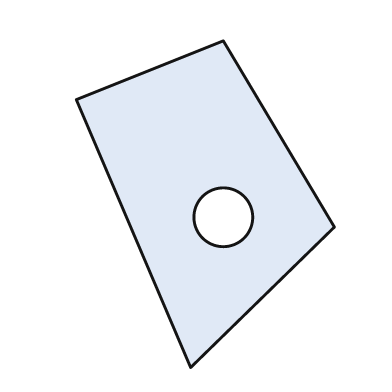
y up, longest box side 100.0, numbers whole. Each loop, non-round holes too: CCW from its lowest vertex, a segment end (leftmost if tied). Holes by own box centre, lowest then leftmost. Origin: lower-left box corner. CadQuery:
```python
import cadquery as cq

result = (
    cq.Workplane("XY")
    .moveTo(35.0, 0.0)
    .lineTo(79.0, 43.0)
    .lineTo(45.0, 100.0)
    .lineTo(0.0, 82.0)
    .close()
    .moveTo(45.0, 46.0)
    .circle(9.0)
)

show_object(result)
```